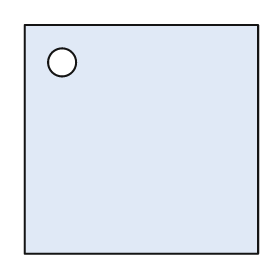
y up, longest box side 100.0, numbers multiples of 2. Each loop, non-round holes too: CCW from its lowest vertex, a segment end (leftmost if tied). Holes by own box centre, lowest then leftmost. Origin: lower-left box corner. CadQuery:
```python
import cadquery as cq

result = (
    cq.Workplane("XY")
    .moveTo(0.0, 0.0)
    .lineTo(100.0, 0.0)
    .lineTo(100.0, 98.0)
    .lineTo(0.0, 98.0)
    .close()
    .moveTo(16.0, 82.0)
    .circle(6.0)
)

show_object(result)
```